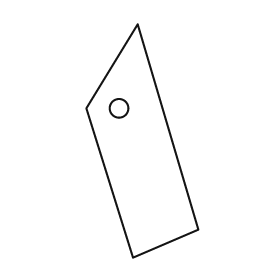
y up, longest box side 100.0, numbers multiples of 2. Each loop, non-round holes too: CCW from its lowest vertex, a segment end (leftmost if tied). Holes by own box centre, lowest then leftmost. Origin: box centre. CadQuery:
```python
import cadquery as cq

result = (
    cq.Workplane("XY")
    .moveTo(-4.0, -50.0)
    .lineTo(24.0, -38.0)
    .lineTo(-2.0, 50.0)
    .lineTo(-24.0, 14.0)
    .close()
    .moveTo(-10.0, 14.0)
    .circle(4.0)
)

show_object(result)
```